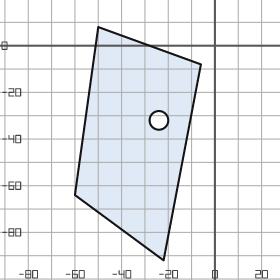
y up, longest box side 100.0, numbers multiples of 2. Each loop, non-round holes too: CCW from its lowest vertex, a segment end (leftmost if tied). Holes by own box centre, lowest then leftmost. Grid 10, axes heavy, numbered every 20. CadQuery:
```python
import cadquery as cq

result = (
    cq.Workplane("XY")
    .moveTo(-22.0, -92.0)
    .lineTo(-6.0, -8.0)
    .lineTo(-50.0, 8.0)
    .lineTo(-60.0, -64.0)
    .close()
    .moveTo(-24.0, -32.0)
    .circle(4.0)
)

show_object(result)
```